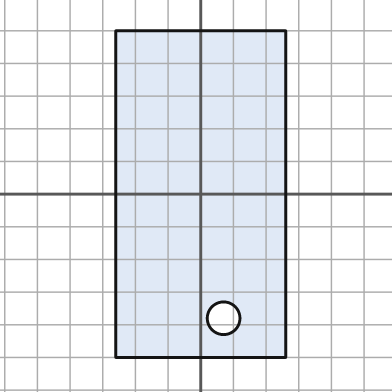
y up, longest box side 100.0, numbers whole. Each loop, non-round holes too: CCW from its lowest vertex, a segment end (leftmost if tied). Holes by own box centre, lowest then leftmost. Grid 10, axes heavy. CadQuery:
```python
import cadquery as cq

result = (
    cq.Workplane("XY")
    .moveTo(-26.0, -50.0)
    .lineTo(26.0, -50.0)
    .lineTo(26.0, 50.0)
    .lineTo(-26.0, 50.0)
    .close()
    .moveTo(7.0, -38.0)
    .circle(5.0)
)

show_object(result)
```